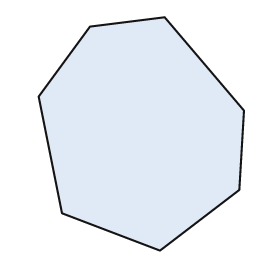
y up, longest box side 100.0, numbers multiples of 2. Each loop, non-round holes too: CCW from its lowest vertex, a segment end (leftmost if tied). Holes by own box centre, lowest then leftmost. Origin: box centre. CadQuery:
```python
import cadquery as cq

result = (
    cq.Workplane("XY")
    .moveTo(8.0, -50.0)
    .lineTo(42.0, -24.0)
    .lineTo(44.0, 10.0)
    .lineTo(10.0, 50.0)
    .lineTo(-22.0, 46.0)
    .lineTo(-44.0, 16.0)
    .lineTo(-34.0, -34.0)
    .close()
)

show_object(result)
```